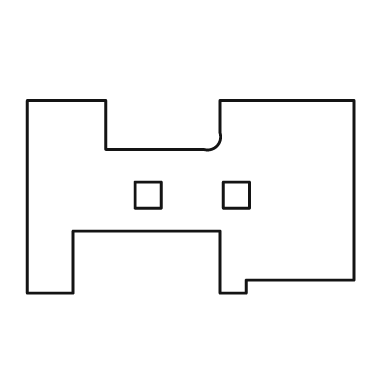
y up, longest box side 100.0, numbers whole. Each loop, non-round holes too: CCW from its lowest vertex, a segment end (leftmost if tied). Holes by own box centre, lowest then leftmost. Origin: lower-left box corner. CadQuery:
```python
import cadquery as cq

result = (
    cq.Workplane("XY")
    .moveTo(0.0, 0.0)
    .lineTo(14.0, 0.0)
    .lineTo(14.0, 19.0)
    .lineTo(59.0, 19.0)
    .lineTo(59.0, 0.0)
    .lineTo(67.0, 0.0)
    .lineTo(67.0, 4.0)
    .lineTo(100.0, 4.0)
    .lineTo(100.0, 59.0)
    .lineTo(59.0, 59.0)
    .lineTo(59.0, 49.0)
    .threePointArc((58.0, 45.0), (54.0, 44.0))
    .lineTo(24.0, 44.0)
    .lineTo(24.0, 59.0)
    .lineTo(0.0, 59.0)
    .close()
    .moveTo(33.0, 26.0)
    .lineTo(41.0, 26.0)
    .lineTo(41.0, 34.0)
    .lineTo(33.0, 34.0)
    .close()
    .moveTo(60.0, 26.0)
    .lineTo(68.0, 26.0)
    .lineTo(68.0, 34.0)
    .lineTo(60.0, 34.0)
    .close()
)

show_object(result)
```